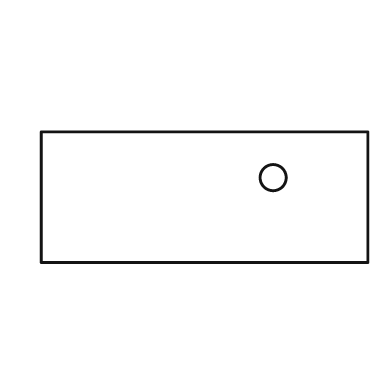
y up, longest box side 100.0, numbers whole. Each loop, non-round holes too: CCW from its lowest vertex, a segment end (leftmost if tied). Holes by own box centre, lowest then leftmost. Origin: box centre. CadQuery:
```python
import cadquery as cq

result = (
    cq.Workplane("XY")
    .moveTo(-50.0, -20.0)
    .lineTo(50.0, -20.0)
    .lineTo(50.0, 20.0)
    .lineTo(-50.0, 20.0)
    .close()
    .moveTo(21.0, 6.0)
    .circle(4.0)
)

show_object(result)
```